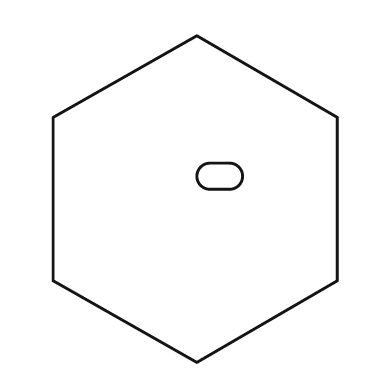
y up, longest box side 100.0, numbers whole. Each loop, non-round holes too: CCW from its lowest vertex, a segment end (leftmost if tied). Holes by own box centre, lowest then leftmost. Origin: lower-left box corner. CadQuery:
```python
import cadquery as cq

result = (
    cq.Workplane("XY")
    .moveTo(44.0, 0.0)
    .lineTo(87.0, 25.0)
    .lineTo(87.0, 75.0)
    .lineTo(44.0, 100.0)
    .lineTo(0.0, 75.0)
    .lineTo(0.0, 25.0)
    .close()
    .moveTo(48.0, 53.0)
    .lineTo(54.0, 53.0)
    .threePointArc((58.0, 57.0), (54.0, 61.0))
    .lineTo(48.0, 61.0)
    .threePointArc((44.0, 57.0), (48.0, 53.0))
    .close()
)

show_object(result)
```